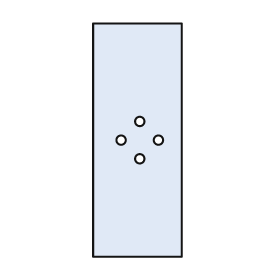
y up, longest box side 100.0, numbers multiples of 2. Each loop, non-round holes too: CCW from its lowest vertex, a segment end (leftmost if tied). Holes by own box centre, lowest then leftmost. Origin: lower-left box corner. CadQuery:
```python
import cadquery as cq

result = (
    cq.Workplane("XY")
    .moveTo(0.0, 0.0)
    .lineTo(38.0, 0.0)
    .lineTo(38.0, 100.0)
    .lineTo(0.0, 100.0)
    .close()
    .moveTo(20.0, 42.0)
    .circle(2.0)
    .moveTo(12.0, 50.0)
    .circle(2.0)
    .moveTo(28.0, 50.0)
    .circle(2.0)
    .moveTo(20.0, 58.0)
    .circle(2.0)
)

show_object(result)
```